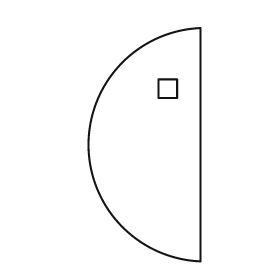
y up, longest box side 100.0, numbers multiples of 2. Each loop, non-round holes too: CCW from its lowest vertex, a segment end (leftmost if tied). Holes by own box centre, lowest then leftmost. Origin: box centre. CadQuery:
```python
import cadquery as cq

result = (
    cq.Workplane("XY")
    .moveTo(24.0, -50.0)
    .lineTo(24.0, 50.0)
    .threePointArc((-24.0, 0.0), (24.0, -50.0))
    .close()
    .moveTo(6.0, 20.0)
    .lineTo(14.0, 20.0)
    .lineTo(14.0, 28.0)
    .lineTo(6.0, 28.0)
    .close()
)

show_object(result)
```